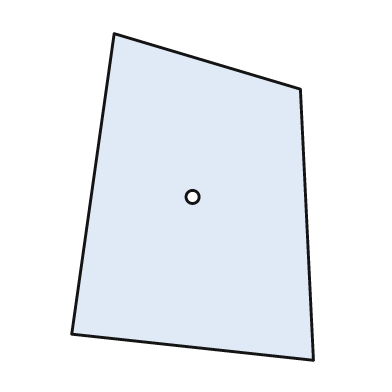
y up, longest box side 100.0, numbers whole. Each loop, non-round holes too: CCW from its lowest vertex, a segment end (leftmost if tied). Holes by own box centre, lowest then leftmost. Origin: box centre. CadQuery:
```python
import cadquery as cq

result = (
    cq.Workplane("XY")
    .moveTo(37.0, -50.0)
    .lineTo(33.0, 33.0)
    .lineTo(-24.0, 50.0)
    .lineTo(-37.0, -42.0)
    .close()
    .moveTo(0.0, 0.0)
    .circle(2.0)
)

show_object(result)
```